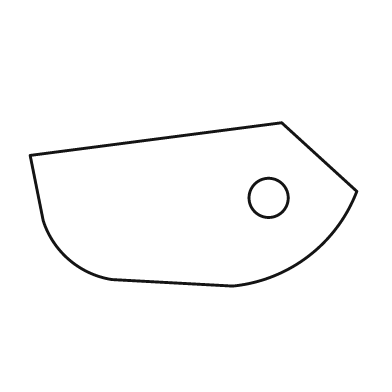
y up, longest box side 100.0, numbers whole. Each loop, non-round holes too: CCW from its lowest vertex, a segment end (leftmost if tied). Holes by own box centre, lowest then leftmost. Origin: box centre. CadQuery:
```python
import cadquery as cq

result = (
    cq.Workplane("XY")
    .moveTo(12.0, -25.0)
    .threePointArc((35.0, -16.0), (50.0, 4.0))
    .lineTo(27.0, 25.0)
    .lineTo(-50.0, 15.0)
    .lineTo(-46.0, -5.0)
    .threePointArc((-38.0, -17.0), (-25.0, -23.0))
    .close()
    .moveTo(23.0, 2.0)
    .circle(6.0)
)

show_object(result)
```